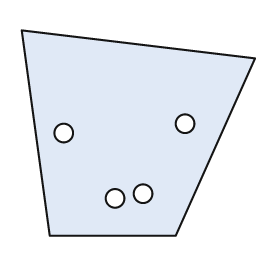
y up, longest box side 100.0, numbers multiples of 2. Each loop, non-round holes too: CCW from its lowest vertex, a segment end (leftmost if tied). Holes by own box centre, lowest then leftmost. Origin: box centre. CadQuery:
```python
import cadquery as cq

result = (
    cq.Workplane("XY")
    .moveTo(-38.0, -44.0)
    .lineTo(16.0, -44.0)
    .lineTo(50.0, 32.0)
    .lineTo(-50.0, 44.0)
    .close()
    .moveTo(-10.0, -28.0)
    .circle(4.0)
    .moveTo(2.0, -26.0)
    .circle(4.0)
    .moveTo(-32.0, 0.0)
    .circle(4.0)
    .moveTo(20.0, 4.0)
    .circle(4.0)
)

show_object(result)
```